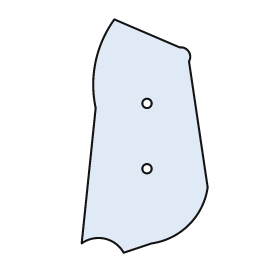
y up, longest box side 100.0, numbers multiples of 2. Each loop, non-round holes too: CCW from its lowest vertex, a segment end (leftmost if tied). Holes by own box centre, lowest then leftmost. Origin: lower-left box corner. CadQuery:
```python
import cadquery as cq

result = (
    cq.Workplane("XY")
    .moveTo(18.0, 0.0)
    .lineTo(30.0, 4.0)
    .threePointArc((46.0, 12.0), (54.0, 28.0))
    .lineTo(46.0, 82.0)
    .threePointArc((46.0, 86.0), (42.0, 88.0))
    .lineTo(14.0, 100.0)
    .threePointArc((6.0, 82.0), (6.0, 62.0))
    .lineTo(0.0, 4.0)
    .threePointArc((10.0, 6.0), (18.0, 0.0))
    .close()
    .moveTo(28.0, 36.0)
    .circle(2.0)
    .moveTo(28.0, 64.0)
    .circle(2.0)
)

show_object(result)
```